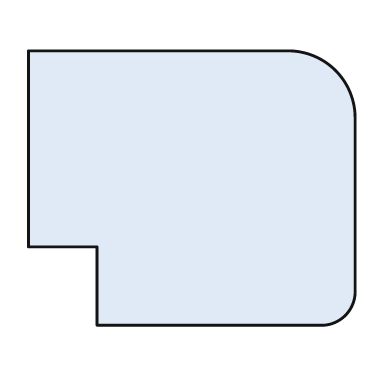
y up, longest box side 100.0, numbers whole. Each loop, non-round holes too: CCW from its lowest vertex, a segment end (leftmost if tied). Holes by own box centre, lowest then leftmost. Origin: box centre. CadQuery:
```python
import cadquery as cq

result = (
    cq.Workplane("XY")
    .moveTo(-29.0, -42.0)
    .lineTo(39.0, -42.0)
    .threePointArc((47.0, -39.0), (50.0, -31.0))
    .lineTo(50.0, 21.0)
    .threePointArc((44.0, 36.0), (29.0, 42.0))
    .lineTo(-50.0, 42.0)
    .lineTo(-50.0, -18.0)
    .lineTo(-29.0, -18.0)
    .close()
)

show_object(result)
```